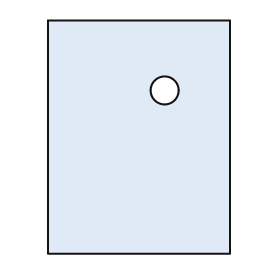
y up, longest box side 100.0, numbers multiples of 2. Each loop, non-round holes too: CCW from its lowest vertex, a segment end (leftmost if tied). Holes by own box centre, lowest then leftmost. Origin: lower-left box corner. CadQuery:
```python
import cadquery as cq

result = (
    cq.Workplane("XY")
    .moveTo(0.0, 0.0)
    .lineTo(78.0, 0.0)
    .lineTo(78.0, 100.0)
    .lineTo(0.0, 100.0)
    .close()
    .moveTo(50.0, 70.0)
    .circle(6.0)
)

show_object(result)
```